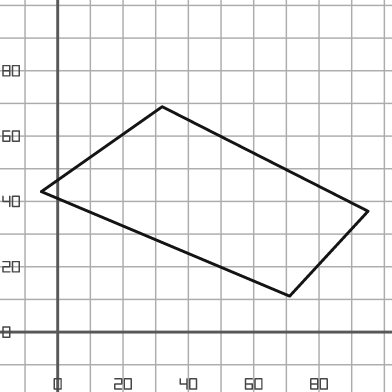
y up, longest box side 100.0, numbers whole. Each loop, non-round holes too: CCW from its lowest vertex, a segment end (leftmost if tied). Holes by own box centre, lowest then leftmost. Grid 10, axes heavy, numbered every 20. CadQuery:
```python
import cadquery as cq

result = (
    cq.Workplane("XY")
    .moveTo(71.0, 11.0)
    .lineTo(95.0, 37.0)
    .lineTo(32.0, 69.0)
    .lineTo(-5.0, 43.0)
    .close()
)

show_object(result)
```